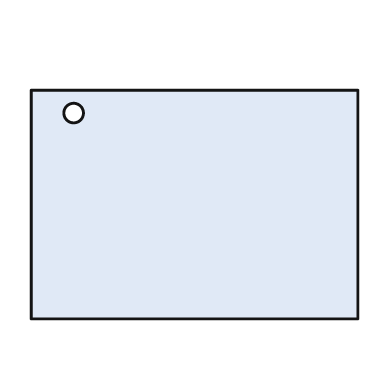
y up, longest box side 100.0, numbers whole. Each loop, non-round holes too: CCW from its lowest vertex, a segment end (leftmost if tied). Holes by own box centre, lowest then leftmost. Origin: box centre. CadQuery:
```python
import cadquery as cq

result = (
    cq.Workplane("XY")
    .moveTo(-50.0, -35.0)
    .lineTo(50.0, -35.0)
    .lineTo(50.0, 35.0)
    .lineTo(-50.0, 35.0)
    .close()
    .moveTo(-37.0, 28.0)
    .circle(3.0)
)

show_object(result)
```